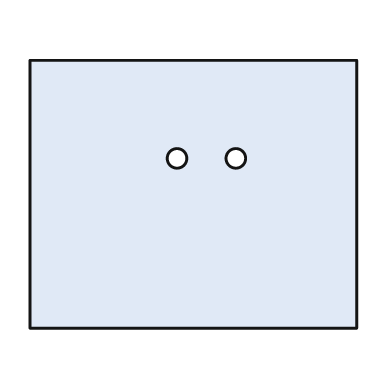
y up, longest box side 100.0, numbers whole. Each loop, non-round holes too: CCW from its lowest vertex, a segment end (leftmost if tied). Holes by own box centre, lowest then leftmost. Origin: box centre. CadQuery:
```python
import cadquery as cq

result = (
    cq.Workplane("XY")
    .moveTo(-50.0, -41.0)
    .lineTo(50.0, -41.0)
    .lineTo(50.0, 41.0)
    .lineTo(-50.0, 41.0)
    .close()
    .moveTo(-5.0, 11.0)
    .circle(3.0)
    .moveTo(13.0, 11.0)
    .circle(3.0)
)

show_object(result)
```